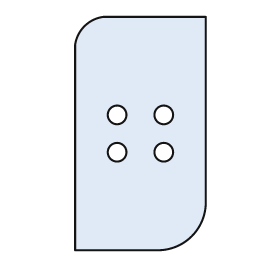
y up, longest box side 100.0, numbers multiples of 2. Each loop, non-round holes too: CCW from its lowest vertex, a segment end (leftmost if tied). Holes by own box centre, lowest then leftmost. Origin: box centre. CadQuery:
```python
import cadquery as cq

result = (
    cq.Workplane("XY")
    .moveTo(-28.0, -50.0)
    .lineTo(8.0, -50.0)
    .threePointArc((22.0, -44.0), (28.0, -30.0))
    .lineTo(28.0, 50.0)
    .lineTo(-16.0, 50.0)
    .threePointArc((-24.0, 46.0), (-28.0, 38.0))
    .close()
    .moveTo(-10.0, -8.0)
    .circle(4.0)
    .moveTo(10.0, -8.0)
    .circle(4.0)
    .moveTo(-10.0, 8.0)
    .circle(4.0)
    .moveTo(10.0, 8.0)
    .circle(4.0)
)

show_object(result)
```